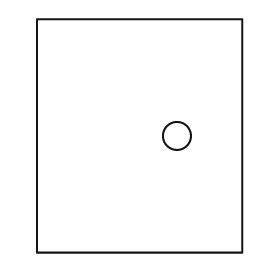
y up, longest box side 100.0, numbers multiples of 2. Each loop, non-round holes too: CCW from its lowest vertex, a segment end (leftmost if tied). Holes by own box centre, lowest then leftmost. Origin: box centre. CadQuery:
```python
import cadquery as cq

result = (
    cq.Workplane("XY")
    .moveTo(-44.0, -50.0)
    .lineTo(44.0, -50.0)
    .lineTo(44.0, 50.0)
    .lineTo(-44.0, 50.0)
    .close()
    .moveTo(16.0, 0.0)
    .circle(6.0)
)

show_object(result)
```